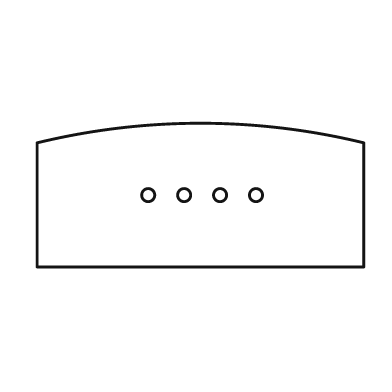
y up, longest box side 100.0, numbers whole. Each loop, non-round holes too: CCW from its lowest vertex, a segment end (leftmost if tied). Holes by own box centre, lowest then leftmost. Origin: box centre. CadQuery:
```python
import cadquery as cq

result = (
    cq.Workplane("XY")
    .moveTo(-50.0, -22.0)
    .lineTo(50.0, -22.0)
    .lineTo(50.0, 16.0)
    .threePointArc((0.0, 22.0), (-50.0, 16.0))
    .close()
    .moveTo(-16.0, 0.0)
    .circle(2.0)
    .moveTo(-5.0, 0.0)
    .circle(2.0)
    .moveTo(6.0, 0.0)
    .circle(2.0)
    .moveTo(17.0, 0.0)
    .circle(2.0)
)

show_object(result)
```